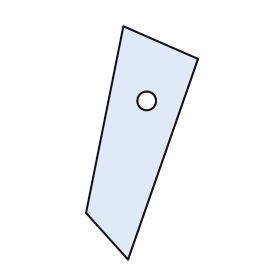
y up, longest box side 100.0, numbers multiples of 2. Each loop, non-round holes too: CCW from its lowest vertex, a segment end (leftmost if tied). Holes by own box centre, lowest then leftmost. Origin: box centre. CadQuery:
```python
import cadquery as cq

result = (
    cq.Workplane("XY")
    .moveTo(-6.0, -50.0)
    .lineTo(24.0, 36.0)
    .lineTo(-8.0, 50.0)
    .lineTo(-24.0, -30.0)
    .close()
    .moveTo(2.0, 18.0)
    .circle(4.0)
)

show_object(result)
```